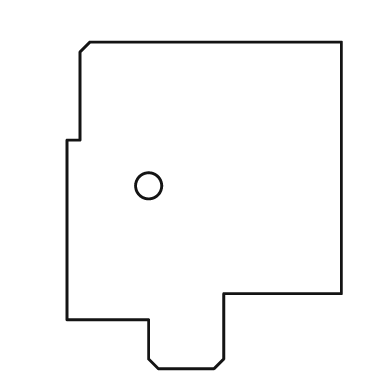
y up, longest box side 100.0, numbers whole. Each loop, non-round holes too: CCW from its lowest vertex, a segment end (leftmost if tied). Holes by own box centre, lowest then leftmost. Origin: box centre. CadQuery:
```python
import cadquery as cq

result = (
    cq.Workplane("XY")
    .moveTo(-14.0, -50.0)
    .lineTo(3.0, -50.0)
    .lineTo(6.0, -47.0)
    .lineTo(6.0, -27.0)
    .lineTo(42.0, -27.0)
    .lineTo(42.0, 50.0)
    .lineTo(-35.0, 50.0)
    .lineTo(-38.0, 47.0)
    .lineTo(-38.0, 20.0)
    .lineTo(-42.0, 20.0)
    .lineTo(-42.0, -35.0)
    .lineTo(-17.0, -35.0)
    .lineTo(-17.0, -47.0)
    .close()
    .moveTo(-17.0, 6.0)
    .circle(4.0)
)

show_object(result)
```